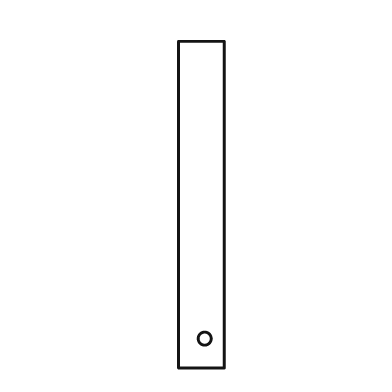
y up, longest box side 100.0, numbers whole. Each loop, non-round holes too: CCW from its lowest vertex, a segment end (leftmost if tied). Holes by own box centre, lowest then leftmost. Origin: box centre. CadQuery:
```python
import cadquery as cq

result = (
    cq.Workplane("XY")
    .moveTo(-7.0, -50.0)
    .lineTo(7.0, -50.0)
    .lineTo(7.0, 50.0)
    .lineTo(-7.0, 50.0)
    .close()
    .moveTo(1.0, -41.0)
    .circle(2.0)
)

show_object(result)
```